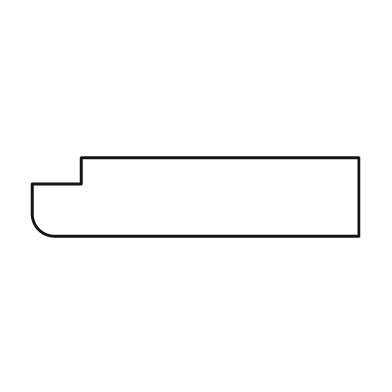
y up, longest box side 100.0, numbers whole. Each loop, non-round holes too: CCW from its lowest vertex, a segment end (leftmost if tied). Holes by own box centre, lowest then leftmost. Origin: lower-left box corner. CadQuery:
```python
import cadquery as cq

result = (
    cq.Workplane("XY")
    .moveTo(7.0, 0.0)
    .lineTo(100.0, 0.0)
    .lineTo(100.0, 24.0)
    .lineTo(15.0, 24.0)
    .lineTo(15.0, 16.0)
    .lineTo(0.0, 16.0)
    .lineTo(0.0, 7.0)
    .threePointArc((2.0, 2.0), (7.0, 0.0))
    .close()
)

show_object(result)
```